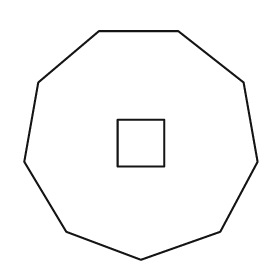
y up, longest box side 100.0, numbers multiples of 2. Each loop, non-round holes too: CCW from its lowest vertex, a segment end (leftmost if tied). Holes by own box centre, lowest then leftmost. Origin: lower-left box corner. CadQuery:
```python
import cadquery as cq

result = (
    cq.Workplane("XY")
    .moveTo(50.0, 0.0)
    .lineTo(84.0, 12.0)
    .lineTo(100.0, 42.0)
    .lineTo(94.0, 76.0)
    .lineTo(66.0, 98.0)
    .lineTo(32.0, 98.0)
    .lineTo(6.0, 76.0)
    .lineTo(0.0, 42.0)
    .lineTo(18.0, 12.0)
    .close()
    .moveTo(40.0, 40.0)
    .lineTo(60.0, 40.0)
    .lineTo(60.0, 60.0)
    .lineTo(40.0, 60.0)
    .close()
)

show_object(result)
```